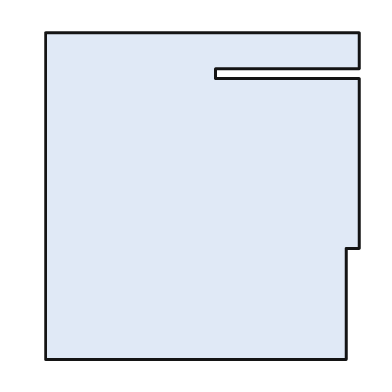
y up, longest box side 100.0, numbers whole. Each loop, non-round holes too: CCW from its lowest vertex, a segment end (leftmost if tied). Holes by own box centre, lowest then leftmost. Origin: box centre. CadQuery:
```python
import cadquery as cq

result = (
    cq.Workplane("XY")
    .moveTo(-48.0, -50.0)
    .lineTo(44.0, -50.0)
    .lineTo(44.0, -16.0)
    .lineTo(48.0, -16.0)
    .lineTo(48.0, 36.0)
    .lineTo(4.0, 36.0)
    .lineTo(4.0, 39.0)
    .lineTo(48.0, 39.0)
    .lineTo(48.0, 50.0)
    .lineTo(-48.0, 50.0)
    .close()
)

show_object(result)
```